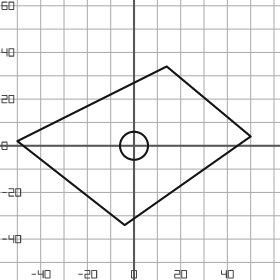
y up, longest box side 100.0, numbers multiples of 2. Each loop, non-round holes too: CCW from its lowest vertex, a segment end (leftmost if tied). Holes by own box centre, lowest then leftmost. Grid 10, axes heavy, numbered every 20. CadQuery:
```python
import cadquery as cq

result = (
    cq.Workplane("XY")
    .moveTo(-4.0, -34.0)
    .lineTo(50.0, 4.0)
    .lineTo(14.0, 34.0)
    .lineTo(-50.0, 2.0)
    .close()
    .moveTo(0.0, 0.0)
    .circle(6.0)
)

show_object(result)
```